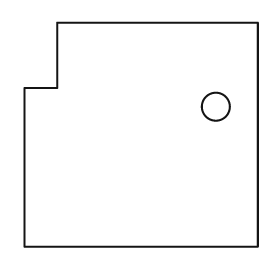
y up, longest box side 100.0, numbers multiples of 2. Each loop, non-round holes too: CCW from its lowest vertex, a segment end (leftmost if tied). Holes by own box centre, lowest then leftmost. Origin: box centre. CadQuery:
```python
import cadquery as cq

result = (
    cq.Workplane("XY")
    .moveTo(-50.0, -48.0)
    .lineTo(50.0, -48.0)
    .lineTo(50.0, 48.0)
    .lineTo(-36.0, 48.0)
    .lineTo(-36.0, 20.0)
    .lineTo(-50.0, 20.0)
    .close()
    .moveTo(32.0, 12.0)
    .circle(6.0)
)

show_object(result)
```